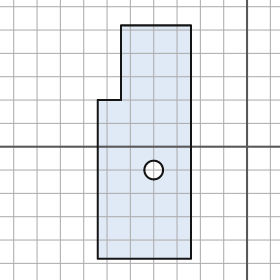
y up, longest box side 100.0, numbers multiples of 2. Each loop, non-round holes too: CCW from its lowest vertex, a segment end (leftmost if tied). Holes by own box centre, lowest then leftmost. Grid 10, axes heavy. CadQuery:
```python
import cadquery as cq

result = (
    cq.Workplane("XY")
    .moveTo(-64.0, -48.0)
    .lineTo(-24.0, -48.0)
    .lineTo(-24.0, 52.0)
    .lineTo(-54.0, 52.0)
    .lineTo(-54.0, 20.0)
    .lineTo(-64.0, 20.0)
    .close()
    .moveTo(-40.0, -10.0)
    .circle(4.0)
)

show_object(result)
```